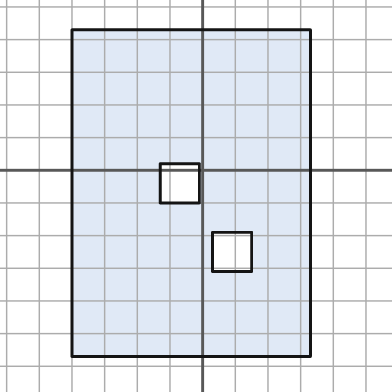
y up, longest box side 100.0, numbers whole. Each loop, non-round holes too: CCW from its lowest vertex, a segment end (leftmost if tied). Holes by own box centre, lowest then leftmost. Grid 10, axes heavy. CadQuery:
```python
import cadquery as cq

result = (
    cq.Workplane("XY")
    .moveTo(-40.0, -57.0)
    .lineTo(33.0, -57.0)
    .lineTo(33.0, 43.0)
    .lineTo(-40.0, 43.0)
    .close()
    .moveTo(3.0, -31.0)
    .lineTo(15.0, -31.0)
    .lineTo(15.0, -19.0)
    .lineTo(3.0, -19.0)
    .close()
    .moveTo(-13.0, -10.0)
    .lineTo(-1.0, -10.0)
    .lineTo(-1.0, 2.0)
    .lineTo(-13.0, 2.0)
    .close()
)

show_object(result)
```